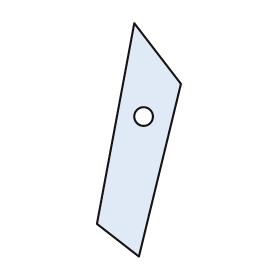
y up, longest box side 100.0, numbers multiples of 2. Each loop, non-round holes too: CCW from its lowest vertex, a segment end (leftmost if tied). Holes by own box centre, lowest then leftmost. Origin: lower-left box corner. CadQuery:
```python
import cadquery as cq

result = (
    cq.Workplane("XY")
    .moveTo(18.0, 0.0)
    .lineTo(36.0, 74.0)
    .lineTo(16.0, 100.0)
    .lineTo(0.0, 14.0)
    .close()
    .moveTo(20.0, 60.0)
    .circle(4.0)
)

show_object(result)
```